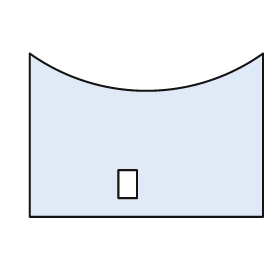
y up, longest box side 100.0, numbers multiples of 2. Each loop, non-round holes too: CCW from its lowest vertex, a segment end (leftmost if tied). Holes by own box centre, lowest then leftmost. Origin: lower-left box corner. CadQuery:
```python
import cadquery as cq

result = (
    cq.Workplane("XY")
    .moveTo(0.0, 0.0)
    .lineTo(100.0, 0.0)
    .lineTo(100.0, 70.0)
    .threePointArc((50.0, 54.0), (0.0, 70.0))
    .close()
    .moveTo(38.0, 8.0)
    .lineTo(46.0, 8.0)
    .lineTo(46.0, 20.0)
    .lineTo(38.0, 20.0)
    .close()
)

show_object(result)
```